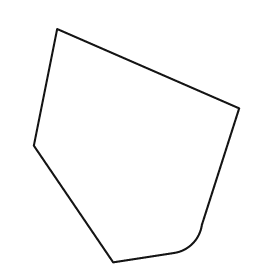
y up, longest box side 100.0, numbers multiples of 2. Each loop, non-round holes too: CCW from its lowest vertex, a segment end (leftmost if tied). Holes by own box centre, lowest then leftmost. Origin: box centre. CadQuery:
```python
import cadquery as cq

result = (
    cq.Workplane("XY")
    .moveTo(-10.0, -50.0)
    .lineTo(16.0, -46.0)
    .threePointArc((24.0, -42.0), (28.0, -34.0))
    .lineTo(44.0, 16.0)
    .lineTo(-34.0, 50.0)
    .lineTo(-44.0, 0.0)
    .close()
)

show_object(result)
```